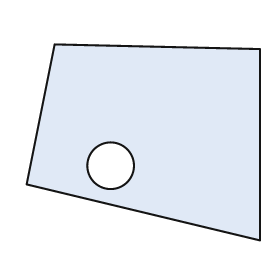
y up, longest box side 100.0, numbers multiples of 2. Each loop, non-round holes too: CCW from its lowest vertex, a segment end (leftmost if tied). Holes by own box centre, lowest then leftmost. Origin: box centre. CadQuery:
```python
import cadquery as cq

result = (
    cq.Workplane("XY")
    .moveTo(50.0, -42.0)
    .lineTo(50.0, 40.0)
    .lineTo(-38.0, 42.0)
    .lineTo(-50.0, -18.0)
    .close()
    .moveTo(-14.0, -10.0)
    .circle(10.0)
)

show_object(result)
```